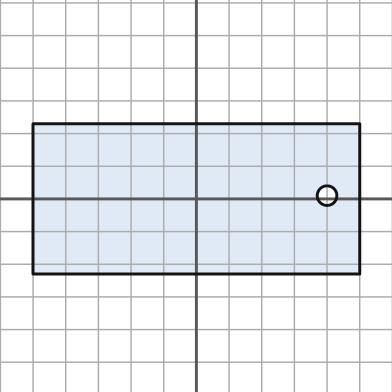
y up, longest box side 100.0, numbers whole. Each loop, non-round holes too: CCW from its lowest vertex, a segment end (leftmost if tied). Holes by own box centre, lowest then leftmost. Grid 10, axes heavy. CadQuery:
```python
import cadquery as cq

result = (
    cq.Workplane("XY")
    .moveTo(-50.0, -23.0)
    .lineTo(50.0, -23.0)
    .lineTo(50.0, 23.0)
    .lineTo(-50.0, 23.0)
    .close()
    .moveTo(40.0, 1.0)
    .circle(3.0)
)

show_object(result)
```